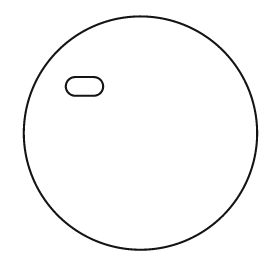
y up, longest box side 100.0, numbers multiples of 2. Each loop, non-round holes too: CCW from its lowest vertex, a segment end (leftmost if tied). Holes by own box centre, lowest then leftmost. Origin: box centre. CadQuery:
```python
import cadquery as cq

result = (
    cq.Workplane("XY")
    .moveTo(0.0, 0.0)
    .circle(50.0)
    .moveTo(-28.0, 16.0)
    .lineTo(-20.0, 16.0)
    .threePointArc((-16.0, 20.0), (-20.0, 24.0))
    .lineTo(-28.0, 24.0)
    .threePointArc((-32.0, 20.0), (-28.0, 16.0))
    .close()
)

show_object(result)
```